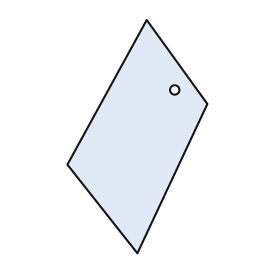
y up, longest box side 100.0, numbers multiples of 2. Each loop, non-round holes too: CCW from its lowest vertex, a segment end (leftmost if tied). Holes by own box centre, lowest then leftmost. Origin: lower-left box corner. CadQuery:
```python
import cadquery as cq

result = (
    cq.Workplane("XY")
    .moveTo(30.0, 0.0)
    .lineTo(60.0, 64.0)
    .lineTo(34.0, 100.0)
    .lineTo(0.0, 38.0)
    .close()
    .moveTo(46.0, 70.0)
    .circle(2.0)
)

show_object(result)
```